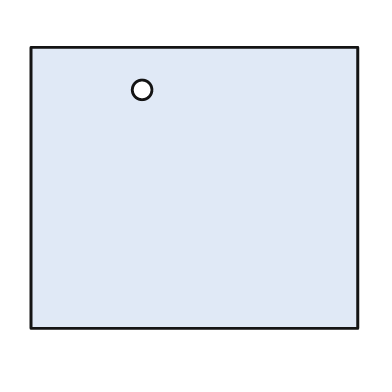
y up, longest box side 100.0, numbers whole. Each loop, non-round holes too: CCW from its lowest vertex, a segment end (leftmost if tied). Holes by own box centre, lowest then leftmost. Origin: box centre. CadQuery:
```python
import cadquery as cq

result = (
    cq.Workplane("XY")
    .moveTo(-50.0, -43.0)
    .lineTo(50.0, -43.0)
    .lineTo(50.0, 43.0)
    .lineTo(-50.0, 43.0)
    .close()
    .moveTo(-16.0, 30.0)
    .circle(3.0)
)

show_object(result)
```